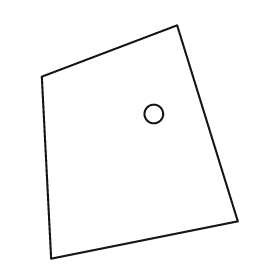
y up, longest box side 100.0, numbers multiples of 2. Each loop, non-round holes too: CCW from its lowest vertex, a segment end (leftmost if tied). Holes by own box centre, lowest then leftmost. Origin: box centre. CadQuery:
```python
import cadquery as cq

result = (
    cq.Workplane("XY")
    .moveTo(-38.0, -50.0)
    .lineTo(42.0, -34.0)
    .lineTo(16.0, 50.0)
    .lineTo(-42.0, 28.0)
    .close()
    .moveTo(6.0, 12.0)
    .circle(4.0)
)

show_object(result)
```